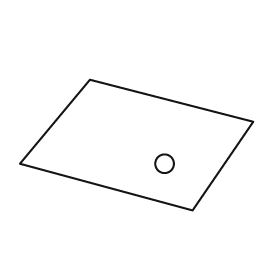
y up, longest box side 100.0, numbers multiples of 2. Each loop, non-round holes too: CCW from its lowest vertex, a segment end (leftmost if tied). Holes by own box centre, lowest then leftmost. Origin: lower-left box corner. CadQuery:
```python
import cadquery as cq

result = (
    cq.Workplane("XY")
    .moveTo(74.0, 0.0)
    .lineTo(100.0, 38.0)
    .lineTo(30.0, 56.0)
    .lineTo(0.0, 20.0)
    .close()
    .moveTo(62.0, 20.0)
    .circle(4.0)
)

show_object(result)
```